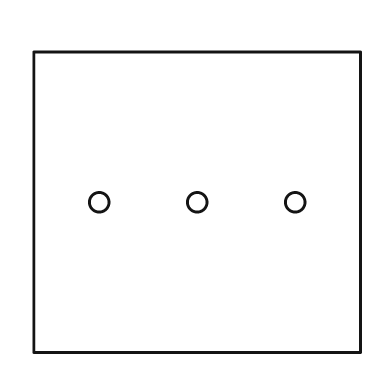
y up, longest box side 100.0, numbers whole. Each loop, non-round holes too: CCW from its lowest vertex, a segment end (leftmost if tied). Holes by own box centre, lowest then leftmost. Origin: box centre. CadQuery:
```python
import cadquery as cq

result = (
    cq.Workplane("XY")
    .moveTo(-50.0, -46.0)
    .lineTo(50.0, -46.0)
    .lineTo(50.0, 46.0)
    .lineTo(-50.0, 46.0)
    .close()
    .moveTo(-30.0, 0.0)
    .circle(3.0)
    .moveTo(0.0, 0.0)
    .circle(3.0)
    .moveTo(30.0, 0.0)
    .circle(3.0)
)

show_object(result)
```